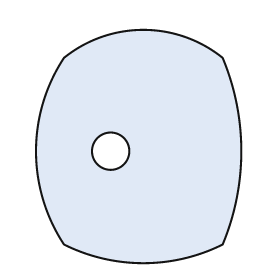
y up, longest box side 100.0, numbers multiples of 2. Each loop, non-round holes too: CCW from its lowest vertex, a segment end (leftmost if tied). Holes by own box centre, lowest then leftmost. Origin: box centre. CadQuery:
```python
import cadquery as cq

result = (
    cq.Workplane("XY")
    .moveTo(-32.0, -42.0)
    .threePointArc((2.0, -50.0), (36.0, -42.0))
    .threePointArc((44.0, -2.0), (36.0, 38.0))
    .threePointArc((2.0, 50.0), (-32.0, 38.0))
    .threePointArc((-44.0, -2.0), (-32.0, -42.0))
    .close()
    .moveTo(-12.0, -2.0)
    .circle(8.0)
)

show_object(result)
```